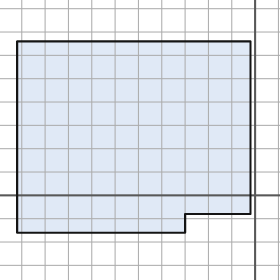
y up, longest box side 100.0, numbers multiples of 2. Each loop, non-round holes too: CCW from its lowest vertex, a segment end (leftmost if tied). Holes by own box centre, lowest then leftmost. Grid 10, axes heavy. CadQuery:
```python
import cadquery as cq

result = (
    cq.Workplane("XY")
    .moveTo(-102.0, -16.0)
    .lineTo(-30.0, -16.0)
    .lineTo(-30.0, -8.0)
    .lineTo(-2.0, -8.0)
    .lineTo(-2.0, 66.0)
    .lineTo(-102.0, 66.0)
    .close()
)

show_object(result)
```